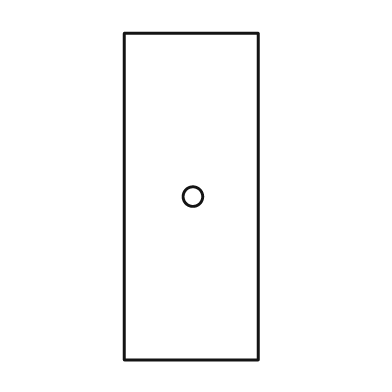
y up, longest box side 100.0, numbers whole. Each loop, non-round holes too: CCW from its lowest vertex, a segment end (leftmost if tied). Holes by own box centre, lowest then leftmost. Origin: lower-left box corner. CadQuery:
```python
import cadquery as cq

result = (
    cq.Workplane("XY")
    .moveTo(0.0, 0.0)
    .lineTo(41.0, 0.0)
    .lineTo(41.0, 100.0)
    .lineTo(0.0, 100.0)
    .close()
    .moveTo(21.0, 50.0)
    .circle(3.0)
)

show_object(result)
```